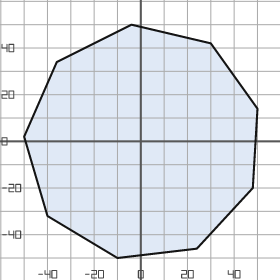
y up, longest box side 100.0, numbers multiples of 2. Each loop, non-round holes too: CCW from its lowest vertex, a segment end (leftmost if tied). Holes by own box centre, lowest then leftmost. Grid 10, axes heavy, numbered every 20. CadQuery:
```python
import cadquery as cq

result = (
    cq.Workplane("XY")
    .moveTo(-10.0, -50.0)
    .lineTo(24.0, -46.0)
    .lineTo(48.0, -20.0)
    .lineTo(50.0, 14.0)
    .lineTo(30.0, 42.0)
    .lineTo(-4.0, 50.0)
    .lineTo(-36.0, 34.0)
    .lineTo(-50.0, 2.0)
    .lineTo(-40.0, -32.0)
    .close()
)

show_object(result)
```